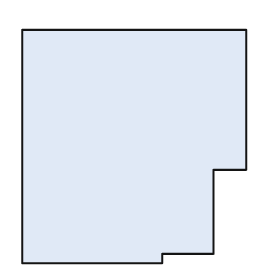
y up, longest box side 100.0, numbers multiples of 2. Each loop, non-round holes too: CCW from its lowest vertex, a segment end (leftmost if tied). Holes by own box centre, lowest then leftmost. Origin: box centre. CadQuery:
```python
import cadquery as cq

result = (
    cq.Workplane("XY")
    .moveTo(-48.0, -50.0)
    .lineTo(12.0, -50.0)
    .lineTo(12.0, -46.0)
    .lineTo(34.0, -46.0)
    .lineTo(34.0, -10.0)
    .lineTo(48.0, -10.0)
    .lineTo(48.0, 50.0)
    .lineTo(-48.0, 50.0)
    .close()
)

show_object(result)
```